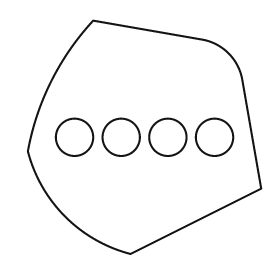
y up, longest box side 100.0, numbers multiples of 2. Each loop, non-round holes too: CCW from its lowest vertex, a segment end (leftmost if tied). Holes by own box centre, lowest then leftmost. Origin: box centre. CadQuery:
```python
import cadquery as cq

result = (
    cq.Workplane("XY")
    .moveTo(-6.0, -50.0)
    .lineTo(50.0, -22.0)
    .lineTo(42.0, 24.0)
    .threePointArc((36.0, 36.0), (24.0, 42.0))
    .lineTo(-22.0, 50.0)
    .threePointArc((-40.0, 24.0), (-50.0, -6.0))
    .threePointArc((-34.0, -34.0), (-6.0, -50.0))
    .close()
    .moveTo(-30.0, 0.0)
    .circle(8.0)
    .moveTo(-10.0, 0.0)
    .circle(8.0)
    .moveTo(10.0, 0.0)
    .circle(8.0)
    .moveTo(30.0, 0.0)
    .circle(8.0)
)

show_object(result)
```